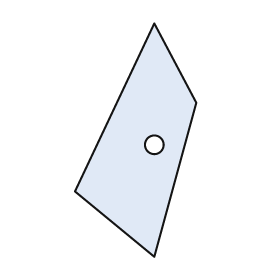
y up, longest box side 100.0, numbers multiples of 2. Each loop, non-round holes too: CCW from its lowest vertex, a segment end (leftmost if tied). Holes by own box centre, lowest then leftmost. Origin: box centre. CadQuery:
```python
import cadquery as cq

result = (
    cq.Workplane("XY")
    .moveTo(8.0, -50.0)
    .lineTo(26.0, 16.0)
    .lineTo(8.0, 50.0)
    .lineTo(-26.0, -22.0)
    .close()
    .moveTo(8.0, -2.0)
    .circle(4.0)
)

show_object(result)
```